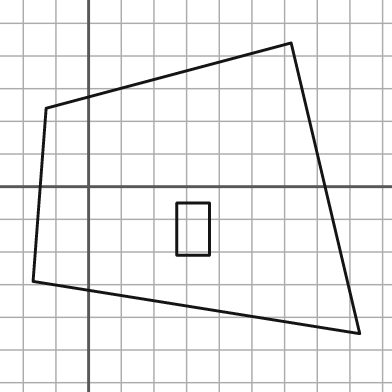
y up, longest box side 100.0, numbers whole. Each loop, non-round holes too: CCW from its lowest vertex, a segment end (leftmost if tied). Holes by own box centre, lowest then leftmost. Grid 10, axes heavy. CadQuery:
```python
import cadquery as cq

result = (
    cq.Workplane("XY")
    .moveTo(83.0, -45.0)
    .lineTo(62.0, 44.0)
    .lineTo(-13.0, 24.0)
    .lineTo(-17.0, -29.0)
    .close()
    .moveTo(27.0, -21.0)
    .lineTo(37.0, -21.0)
    .lineTo(37.0, -5.0)
    .lineTo(27.0, -5.0)
    .close()
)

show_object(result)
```